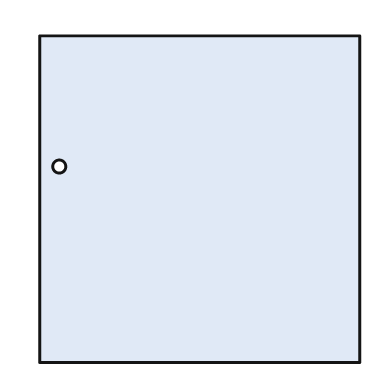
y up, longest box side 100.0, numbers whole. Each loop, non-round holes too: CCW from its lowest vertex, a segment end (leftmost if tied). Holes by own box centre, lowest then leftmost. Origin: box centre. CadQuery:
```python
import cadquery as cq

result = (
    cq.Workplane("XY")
    .moveTo(-49.0, -50.0)
    .lineTo(49.0, -50.0)
    .lineTo(49.0, 50.0)
    .lineTo(-49.0, 50.0)
    .close()
    .moveTo(-43.0, 10.0)
    .circle(2.0)
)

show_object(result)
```